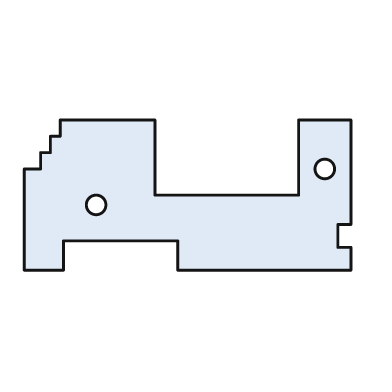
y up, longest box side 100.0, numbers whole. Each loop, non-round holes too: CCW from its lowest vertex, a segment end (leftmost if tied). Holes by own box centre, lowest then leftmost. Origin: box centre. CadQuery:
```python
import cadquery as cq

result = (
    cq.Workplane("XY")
    .moveTo(-50.0, -23.0)
    .lineTo(-38.0, -23.0)
    .lineTo(-38.0, -14.0)
    .lineTo(-3.0, -14.0)
    .lineTo(-3.0, -23.0)
    .lineTo(50.0, -23.0)
    .lineTo(50.0, -16.0)
    .lineTo(46.0, -16.0)
    .lineTo(46.0, -9.0)
    .lineTo(50.0, -9.0)
    .lineTo(50.0, 23.0)
    .lineTo(34.0, 23.0)
    .lineTo(34.0, 0.0)
    .lineTo(-10.0, 0.0)
    .lineTo(-10.0, 23.0)
    .lineTo(-39.0, 23.0)
    .lineTo(-39.0, 18.0)
    .lineTo(-42.0, 18.0)
    .lineTo(-42.0, 13.0)
    .lineTo(-45.0, 13.0)
    .lineTo(-45.0, 8.0)
    .lineTo(-50.0, 8.0)
    .close()
    .moveTo(-28.0, -3.0)
    .circle(3.0)
    .moveTo(42.0, 8.0)
    .circle(3.0)
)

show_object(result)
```